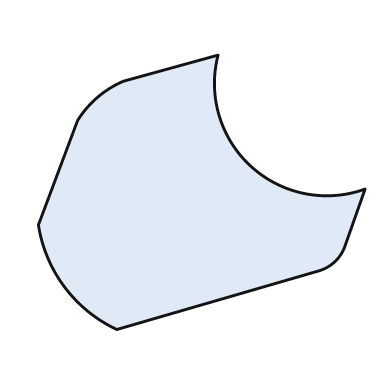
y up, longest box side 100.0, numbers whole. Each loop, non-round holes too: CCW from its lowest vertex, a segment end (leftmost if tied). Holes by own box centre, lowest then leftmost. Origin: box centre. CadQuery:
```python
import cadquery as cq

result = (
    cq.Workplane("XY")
    .moveTo(-26.0, -42.0)
    .lineTo(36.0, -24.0)
    .threePointArc((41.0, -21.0), (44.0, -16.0))
    .lineTo(50.0, 1.0)
    .threePointArc((15.0, 8.0), (5.0, 42.0))
    .lineTo(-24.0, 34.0)
    .threePointArc((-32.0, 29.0), (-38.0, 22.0))
    .lineTo(-50.0, -10.0)
    .threePointArc((-42.0, -29.0), (-26.0, -42.0))
    .close()
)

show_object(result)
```